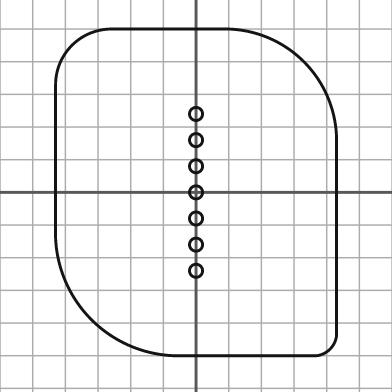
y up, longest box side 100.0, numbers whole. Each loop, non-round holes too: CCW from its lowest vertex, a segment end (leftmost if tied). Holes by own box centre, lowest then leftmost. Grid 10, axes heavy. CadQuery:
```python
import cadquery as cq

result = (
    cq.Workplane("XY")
    .moveTo(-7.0, -50.0)
    .lineTo(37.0, -50.0)
    .threePointArc((41.0, -48.0), (43.0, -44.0))
    .lineTo(43.0, 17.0)
    .threePointArc((33.0, 40.0), (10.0, 50.0))
    .lineTo(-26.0, 50.0)
    .threePointArc((-38.0, 45.0), (-43.0, 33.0))
    .lineTo(-43.0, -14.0)
    .threePointArc((-32.0, -39.0), (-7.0, -50.0))
    .close()
    .moveTo(0.0, -24.0)
    .circle(2.0)
    .moveTo(0.0, -16.0)
    .circle(2.0)
    .moveTo(0.0, -8.0)
    .circle(2.0)
    .moveTo(0.0, 0.0)
    .circle(2.0)
    .moveTo(0.0, 8.0)
    .circle(2.0)
    .moveTo(0.0, 16.0)
    .circle(2.0)
    .moveTo(0.0, 24.0)
    .circle(2.0)
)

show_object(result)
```